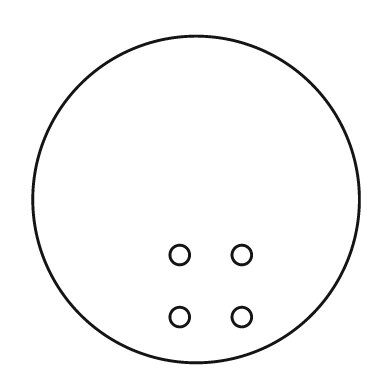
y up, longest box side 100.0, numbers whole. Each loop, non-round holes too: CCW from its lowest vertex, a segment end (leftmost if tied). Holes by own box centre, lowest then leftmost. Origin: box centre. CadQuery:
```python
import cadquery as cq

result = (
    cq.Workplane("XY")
    .moveTo(0.0, 0.0)
    .circle(50.0)
    .moveTo(-5.0, -36.0)
    .circle(3.0)
    .moveTo(14.0, -36.0)
    .circle(3.0)
    .moveTo(-5.0, -17.0)
    .circle(3.0)
    .moveTo(14.0, -17.0)
    .circle(3.0)
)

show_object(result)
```